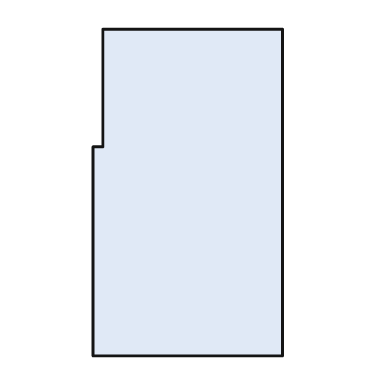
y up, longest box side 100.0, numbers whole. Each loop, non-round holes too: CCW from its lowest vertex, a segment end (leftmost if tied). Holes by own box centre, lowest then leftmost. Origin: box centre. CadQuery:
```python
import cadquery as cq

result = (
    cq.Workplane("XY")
    .moveTo(-29.0, -50.0)
    .lineTo(29.0, -50.0)
    .lineTo(29.0, 50.0)
    .lineTo(-26.0, 50.0)
    .lineTo(-26.0, 14.0)
    .lineTo(-29.0, 14.0)
    .close()
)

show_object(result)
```